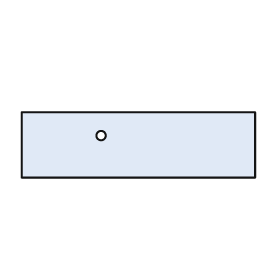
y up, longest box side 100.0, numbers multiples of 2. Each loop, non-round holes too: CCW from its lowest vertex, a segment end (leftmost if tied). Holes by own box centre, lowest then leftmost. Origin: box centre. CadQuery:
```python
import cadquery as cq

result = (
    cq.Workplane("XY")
    .moveTo(-50.0, -14.0)
    .lineTo(50.0, -14.0)
    .lineTo(50.0, 14.0)
    .lineTo(-50.0, 14.0)
    .close()
    .moveTo(-16.0, 4.0)
    .circle(2.0)
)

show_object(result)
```